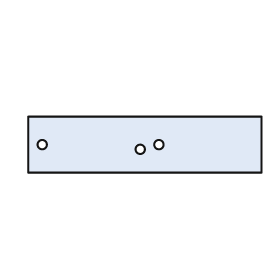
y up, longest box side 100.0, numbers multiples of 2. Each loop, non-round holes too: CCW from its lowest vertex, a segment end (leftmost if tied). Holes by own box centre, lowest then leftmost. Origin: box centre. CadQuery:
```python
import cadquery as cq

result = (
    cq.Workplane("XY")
    .moveTo(-50.0, -12.0)
    .lineTo(50.0, -12.0)
    .lineTo(50.0, 12.0)
    .lineTo(-50.0, 12.0)
    .close()
    .moveTo(-2.0, -2.0)
    .circle(2.0)
    .moveTo(-44.0, 0.0)
    .circle(2.0)
    .moveTo(6.0, 0.0)
    .circle(2.0)
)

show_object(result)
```